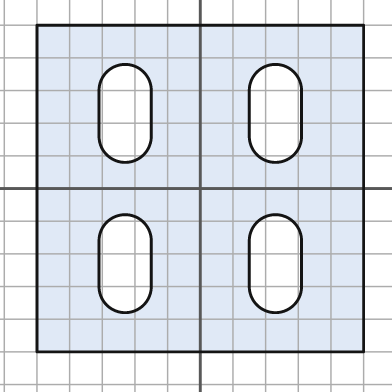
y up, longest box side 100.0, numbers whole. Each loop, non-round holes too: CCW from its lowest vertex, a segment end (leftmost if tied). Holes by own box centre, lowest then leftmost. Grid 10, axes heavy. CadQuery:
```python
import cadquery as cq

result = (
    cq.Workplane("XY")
    .moveTo(-50.0, -50.0)
    .lineTo(50.0, -50.0)
    .lineTo(50.0, 50.0)
    .lineTo(-50.0, 50.0)
    .close()
    .moveTo(-31.0, -30.0)
    .threePointArc((-23.0, -38.0), (-15.0, -30.0))
    .lineTo(-15.0, -16.0)
    .threePointArc((-23.0, -8.0), (-31.0, -16.0))
    .close()
    .moveTo(15.0, -30.0)
    .threePointArc((23.0, -38.0), (31.0, -30.0))
    .lineTo(31.0, -16.0)
    .threePointArc((23.0, -8.0), (15.0, -16.0))
    .close()
    .moveTo(-31.0, 16.0)
    .threePointArc((-23.0, 8.0), (-15.0, 16.0))
    .lineTo(-15.0, 30.0)
    .threePointArc((-23.0, 38.0), (-31.0, 30.0))
    .close()
    .moveTo(15.0, 16.0)
    .threePointArc((23.0, 8.0), (31.0, 16.0))
    .lineTo(31.0, 30.0)
    .threePointArc((23.0, 38.0), (15.0, 30.0))
    .close()
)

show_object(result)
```